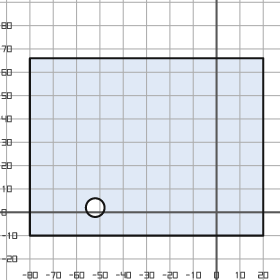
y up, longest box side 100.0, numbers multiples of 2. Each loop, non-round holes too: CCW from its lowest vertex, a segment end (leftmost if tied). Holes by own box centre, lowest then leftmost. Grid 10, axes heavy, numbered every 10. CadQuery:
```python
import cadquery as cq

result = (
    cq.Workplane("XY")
    .moveTo(-80.0, -10.0)
    .lineTo(20.0, -10.0)
    .lineTo(20.0, 66.0)
    .lineTo(-80.0, 66.0)
    .close()
    .moveTo(-52.0, 2.0)
    .circle(4.0)
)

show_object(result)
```